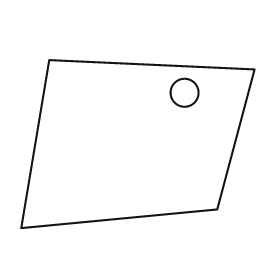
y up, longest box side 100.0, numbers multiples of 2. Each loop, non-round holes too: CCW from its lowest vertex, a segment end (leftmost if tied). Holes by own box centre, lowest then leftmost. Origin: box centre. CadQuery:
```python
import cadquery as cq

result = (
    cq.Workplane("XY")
    .moveTo(-50.0, -36.0)
    .lineTo(34.0, -28.0)
    .lineTo(50.0, 32.0)
    .lineTo(-38.0, 36.0)
    .close()
    .moveTo(20.0, 22.0)
    .circle(6.0)
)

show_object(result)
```